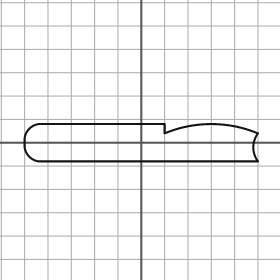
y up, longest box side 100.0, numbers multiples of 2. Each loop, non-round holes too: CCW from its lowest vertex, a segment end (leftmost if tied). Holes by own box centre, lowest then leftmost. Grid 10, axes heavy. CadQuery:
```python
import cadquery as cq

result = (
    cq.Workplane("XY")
    .moveTo(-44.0, -8.0)
    .lineTo(50.0, -8.0)
    .threePointArc((48.0, -2.0), (50.0, 4.0))
    .threePointArc((30.0, 8.0), (10.0, 4.0))
    .lineTo(10.0, 8.0)
    .lineTo(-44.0, 8.0)
    .threePointArc((-48.0, 6.0), (-50.0, 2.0))
    .lineTo(-50.0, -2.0)
    .threePointArc((-48.0, -6.0), (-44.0, -8.0))
    .close()
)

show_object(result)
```